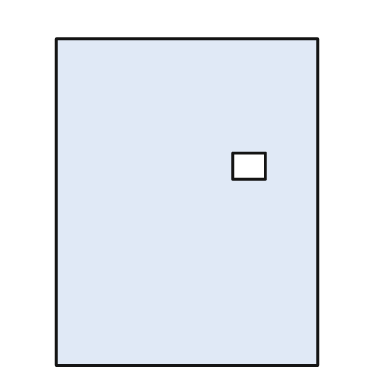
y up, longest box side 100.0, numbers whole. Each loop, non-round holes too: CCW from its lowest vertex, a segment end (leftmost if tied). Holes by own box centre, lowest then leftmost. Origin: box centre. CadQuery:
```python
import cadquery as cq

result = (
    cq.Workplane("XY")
    .moveTo(-40.0, -50.0)
    .lineTo(40.0, -50.0)
    .lineTo(40.0, 50.0)
    .lineTo(-40.0, 50.0)
    .close()
    .moveTo(14.0, 7.0)
    .lineTo(24.0, 7.0)
    .lineTo(24.0, 15.0)
    .lineTo(14.0, 15.0)
    .close()
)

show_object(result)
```